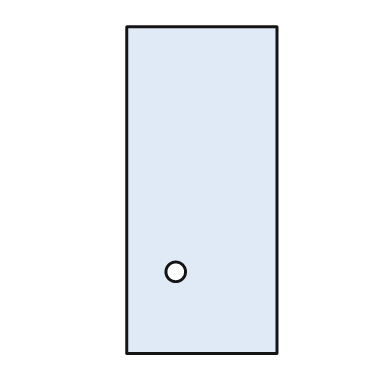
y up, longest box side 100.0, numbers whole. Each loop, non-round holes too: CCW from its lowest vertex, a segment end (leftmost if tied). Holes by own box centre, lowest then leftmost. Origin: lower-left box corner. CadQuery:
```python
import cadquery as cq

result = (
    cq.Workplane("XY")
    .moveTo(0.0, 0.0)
    .lineTo(46.0, 0.0)
    .lineTo(46.0, 100.0)
    .lineTo(0.0, 100.0)
    .close()
    .moveTo(15.0, 25.0)
    .circle(3.0)
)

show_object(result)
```